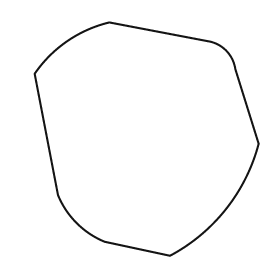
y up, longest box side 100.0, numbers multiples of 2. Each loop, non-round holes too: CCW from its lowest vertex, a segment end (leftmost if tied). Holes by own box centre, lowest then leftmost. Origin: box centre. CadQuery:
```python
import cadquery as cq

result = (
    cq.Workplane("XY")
    .moveTo(10.0, -50.0)
    .threePointArc((34.0, -30.0), (48.0, -2.0))
    .lineTo(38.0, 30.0)
    .threePointArc((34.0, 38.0), (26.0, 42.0))
    .lineTo(-16.0, 50.0)
    .threePointArc((-34.0, 42.0), (-48.0, 28.0))
    .lineTo(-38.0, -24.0)
    .threePointArc((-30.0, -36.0), (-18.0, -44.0))
    .close()
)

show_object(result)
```